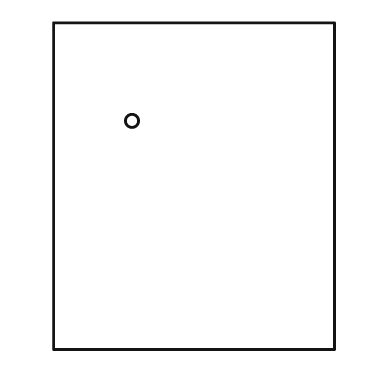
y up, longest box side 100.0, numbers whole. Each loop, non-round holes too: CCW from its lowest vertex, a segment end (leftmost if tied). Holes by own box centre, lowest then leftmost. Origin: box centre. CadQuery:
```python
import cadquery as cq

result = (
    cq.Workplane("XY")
    .moveTo(-43.0, -50.0)
    .lineTo(43.0, -50.0)
    .lineTo(43.0, 50.0)
    .lineTo(-43.0, 50.0)
    .close()
    .moveTo(-19.0, 20.0)
    .circle(2.0)
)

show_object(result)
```